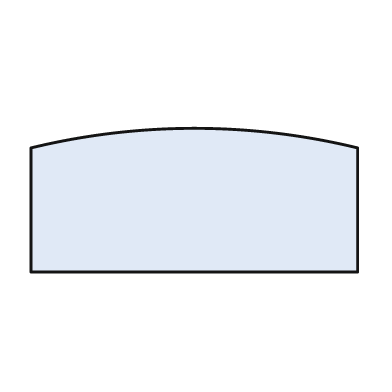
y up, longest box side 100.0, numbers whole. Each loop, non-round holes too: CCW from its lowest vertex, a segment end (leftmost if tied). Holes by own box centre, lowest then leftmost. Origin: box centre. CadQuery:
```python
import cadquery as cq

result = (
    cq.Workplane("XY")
    .moveTo(-50.0, -22.0)
    .lineTo(50.0, -22.0)
    .lineTo(50.0, 16.0)
    .threePointArc((0.0, 22.0), (-50.0, 16.0))
    .close()
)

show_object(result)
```